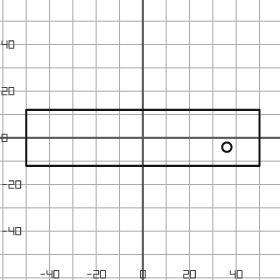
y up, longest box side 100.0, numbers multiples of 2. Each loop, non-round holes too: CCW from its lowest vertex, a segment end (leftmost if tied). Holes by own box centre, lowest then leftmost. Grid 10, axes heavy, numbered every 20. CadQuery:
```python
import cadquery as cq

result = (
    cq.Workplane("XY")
    .moveTo(-50.0, -12.0)
    .lineTo(50.0, -12.0)
    .lineTo(50.0, 12.0)
    .lineTo(-50.0, 12.0)
    .close()
    .moveTo(36.0, -4.0)
    .circle(2.0)
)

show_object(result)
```